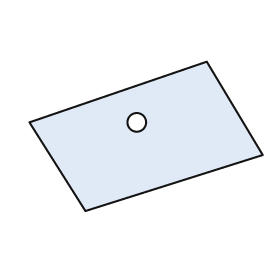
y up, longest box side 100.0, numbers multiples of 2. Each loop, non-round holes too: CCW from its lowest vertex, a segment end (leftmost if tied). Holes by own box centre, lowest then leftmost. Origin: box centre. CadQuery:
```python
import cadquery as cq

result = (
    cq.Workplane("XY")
    .moveTo(-26.0, -32.0)
    .lineTo(50.0, -8.0)
    .lineTo(26.0, 32.0)
    .lineTo(-50.0, 6.0)
    .close()
    .moveTo(-4.0, 6.0)
    .circle(4.0)
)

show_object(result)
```